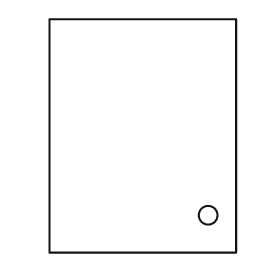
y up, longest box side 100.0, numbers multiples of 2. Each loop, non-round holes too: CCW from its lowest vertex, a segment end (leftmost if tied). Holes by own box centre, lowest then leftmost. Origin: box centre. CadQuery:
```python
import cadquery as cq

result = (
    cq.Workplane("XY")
    .moveTo(-40.0, -50.0)
    .lineTo(40.0, -50.0)
    .lineTo(40.0, 50.0)
    .lineTo(-40.0, 50.0)
    .close()
    .moveTo(28.0, -34.0)
    .circle(4.0)
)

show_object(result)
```